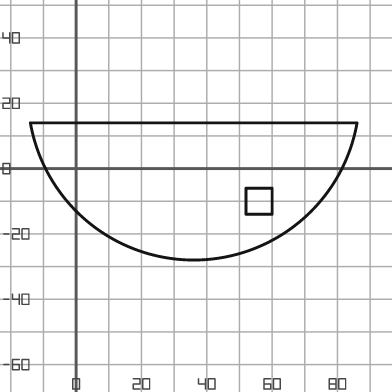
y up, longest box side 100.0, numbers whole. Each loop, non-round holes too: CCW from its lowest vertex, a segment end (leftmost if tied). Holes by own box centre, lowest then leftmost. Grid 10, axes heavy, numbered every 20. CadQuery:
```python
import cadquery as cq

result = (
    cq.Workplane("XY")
    .moveTo(-14.0, 14.0)
    .threePointArc((36.0, -28.0), (86.0, 14.0))
    .close()
    .moveTo(52.0, -14.0)
    .lineTo(60.0, -14.0)
    .lineTo(60.0, -6.0)
    .lineTo(52.0, -6.0)
    .close()
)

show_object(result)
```